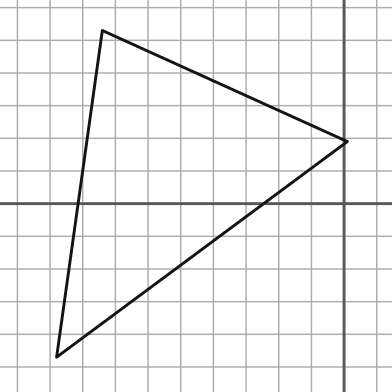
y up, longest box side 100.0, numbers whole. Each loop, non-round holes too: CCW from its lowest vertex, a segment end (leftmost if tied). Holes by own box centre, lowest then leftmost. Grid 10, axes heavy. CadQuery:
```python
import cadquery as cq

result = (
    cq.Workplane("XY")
    .moveTo(-88.0, -47.0)
    .lineTo(1.0, 19.0)
    .lineTo(-74.0, 53.0)
    .close()
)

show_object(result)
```